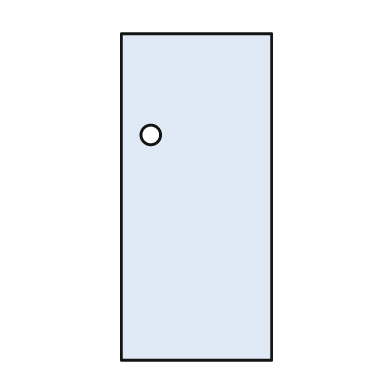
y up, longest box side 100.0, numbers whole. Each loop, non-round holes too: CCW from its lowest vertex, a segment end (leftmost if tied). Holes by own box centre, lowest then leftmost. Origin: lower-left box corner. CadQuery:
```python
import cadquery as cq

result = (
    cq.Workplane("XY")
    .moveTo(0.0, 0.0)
    .lineTo(46.0, 0.0)
    .lineTo(46.0, 100.0)
    .lineTo(0.0, 100.0)
    .close()
    .moveTo(9.0, 69.0)
    .circle(3.0)
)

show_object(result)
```